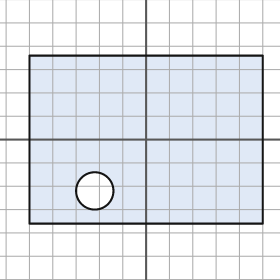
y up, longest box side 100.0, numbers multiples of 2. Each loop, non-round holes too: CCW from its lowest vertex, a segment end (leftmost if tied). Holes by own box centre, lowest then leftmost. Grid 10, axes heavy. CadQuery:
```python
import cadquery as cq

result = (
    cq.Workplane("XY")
    .moveTo(-50.0, -36.0)
    .lineTo(50.0, -36.0)
    .lineTo(50.0, 36.0)
    .lineTo(-50.0, 36.0)
    .close()
    .moveTo(-22.0, -22.0)
    .circle(8.0)
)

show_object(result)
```